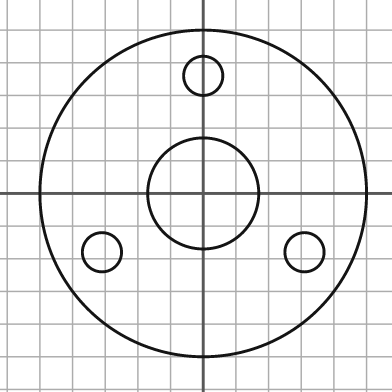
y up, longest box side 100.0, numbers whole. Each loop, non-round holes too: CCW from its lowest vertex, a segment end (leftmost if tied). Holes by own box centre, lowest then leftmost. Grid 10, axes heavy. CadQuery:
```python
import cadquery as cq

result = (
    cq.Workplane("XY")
    .moveTo(0.0, 0.0)
    .circle(50.0)
    .moveTo(-31.0, -18.0)
    .circle(6.0)
    .moveTo(31.0, -18.0)
    .circle(6.0)
    .moveTo(0.0, 0.0)
    .circle(17.0)
    .moveTo(0.0, 36.0)
    .circle(6.0)
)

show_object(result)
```